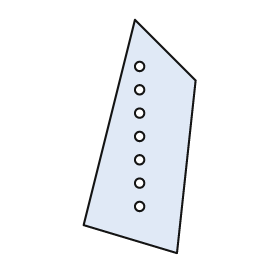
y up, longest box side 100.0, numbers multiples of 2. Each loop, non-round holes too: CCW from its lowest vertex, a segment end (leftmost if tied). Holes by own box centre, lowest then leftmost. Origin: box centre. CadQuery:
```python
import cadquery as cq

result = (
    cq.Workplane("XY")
    .moveTo(16.0, -50.0)
    .lineTo(24.0, 24.0)
    .lineTo(-2.0, 50.0)
    .lineTo(-24.0, -38.0)
    .close()
    .moveTo(0.0, -30.0)
    .circle(2.0)
    .moveTo(0.0, -20.0)
    .circle(2.0)
    .moveTo(0.0, -10.0)
    .circle(2.0)
    .moveTo(0.0, 0.0)
    .circle(2.0)
    .moveTo(0.0, 10.0)
    .circle(2.0)
    .moveTo(0.0, 20.0)
    .circle(2.0)
    .moveTo(0.0, 30.0)
    .circle(2.0)
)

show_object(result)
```